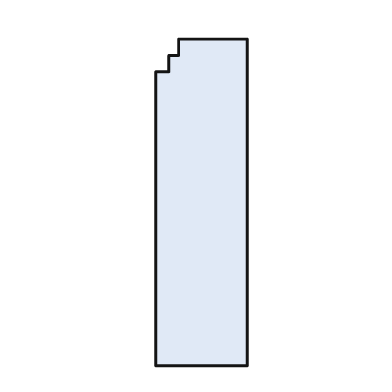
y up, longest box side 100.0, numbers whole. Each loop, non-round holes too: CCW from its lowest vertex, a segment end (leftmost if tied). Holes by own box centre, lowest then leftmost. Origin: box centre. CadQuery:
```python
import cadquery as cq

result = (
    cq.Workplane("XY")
    .moveTo(-14.0, -50.0)
    .lineTo(14.0, -50.0)
    .lineTo(14.0, 50.0)
    .lineTo(-7.0, 50.0)
    .lineTo(-7.0, 45.0)
    .lineTo(-10.0, 45.0)
    .lineTo(-10.0, 40.0)
    .lineTo(-14.0, 40.0)
    .close()
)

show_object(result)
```